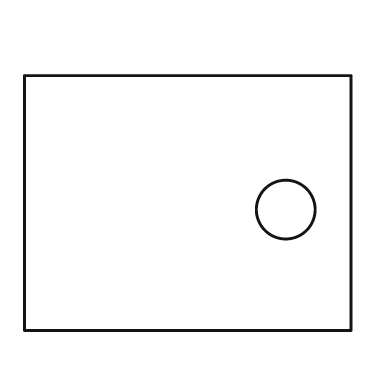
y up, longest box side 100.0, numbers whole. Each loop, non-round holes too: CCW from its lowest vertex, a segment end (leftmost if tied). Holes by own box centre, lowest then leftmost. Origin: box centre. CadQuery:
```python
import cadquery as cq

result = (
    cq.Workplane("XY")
    .moveTo(-50.0, -39.0)
    .lineTo(50.0, -39.0)
    .lineTo(50.0, 39.0)
    .lineTo(-50.0, 39.0)
    .close()
    .moveTo(30.0, -2.0)
    .circle(9.0)
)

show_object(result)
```